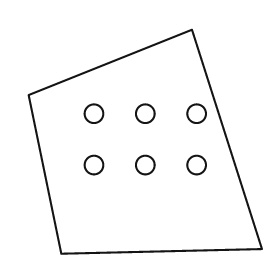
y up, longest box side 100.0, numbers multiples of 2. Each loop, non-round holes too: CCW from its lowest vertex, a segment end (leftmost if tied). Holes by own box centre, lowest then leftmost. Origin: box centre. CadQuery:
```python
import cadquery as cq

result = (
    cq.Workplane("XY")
    .moveTo(-36.0, -48.0)
    .lineTo(50.0, -46.0)
    .lineTo(20.0, 48.0)
    .lineTo(-50.0, 20.0)
    .close()
    .moveTo(-22.0, -10.0)
    .circle(4.0)
    .moveTo(0.0, -10.0)
    .circle(4.0)
    .moveTo(22.0, -10.0)
    .circle(4.0)
    .moveTo(-22.0, 12.0)
    .circle(4.0)
    .moveTo(0.0, 12.0)
    .circle(4.0)
    .moveTo(22.0, 12.0)
    .circle(4.0)
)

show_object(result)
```